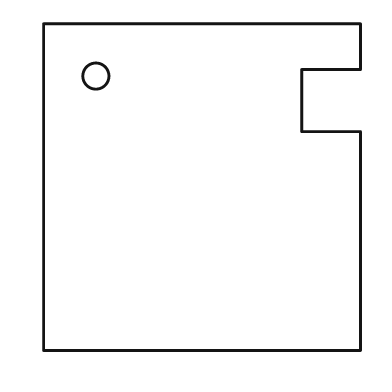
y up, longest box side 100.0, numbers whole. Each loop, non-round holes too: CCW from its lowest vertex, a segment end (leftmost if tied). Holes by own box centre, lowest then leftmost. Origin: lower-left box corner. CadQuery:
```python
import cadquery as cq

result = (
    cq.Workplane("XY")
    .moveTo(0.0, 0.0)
    .lineTo(97.0, 0.0)
    .lineTo(97.0, 67.0)
    .lineTo(79.0, 67.0)
    .lineTo(79.0, 86.0)
    .lineTo(97.0, 86.0)
    .lineTo(97.0, 100.0)
    .lineTo(0.0, 100.0)
    .close()
    .moveTo(16.0, 84.0)
    .circle(4.0)
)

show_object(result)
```